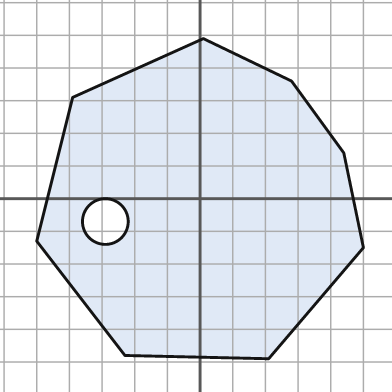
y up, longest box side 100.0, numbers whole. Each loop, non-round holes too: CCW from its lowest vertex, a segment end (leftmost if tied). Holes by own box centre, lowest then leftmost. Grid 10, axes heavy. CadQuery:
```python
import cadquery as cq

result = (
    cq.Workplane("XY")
    .moveTo(21.0, -49.0)
    .lineTo(50.0, -15.0)
    .lineTo(44.0, 14.0)
    .lineTo(28.0, 36.0)
    .lineTo(1.0, 49.0)
    .lineTo(-39.0, 31.0)
    .lineTo(-50.0, -13.0)
    .lineTo(-23.0, -48.0)
    .close()
    .moveTo(-29.0, -7.0)
    .circle(7.0)
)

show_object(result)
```